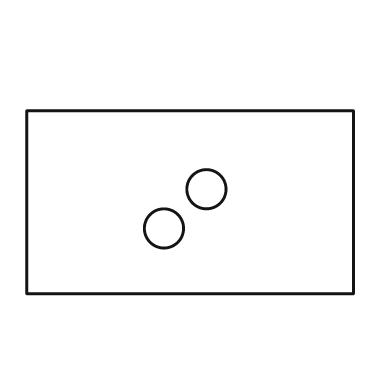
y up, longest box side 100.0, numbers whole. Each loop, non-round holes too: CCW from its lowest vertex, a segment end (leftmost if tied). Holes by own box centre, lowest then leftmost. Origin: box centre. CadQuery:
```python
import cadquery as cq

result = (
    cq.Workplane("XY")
    .moveTo(-50.0, -28.0)
    .lineTo(50.0, -28.0)
    .lineTo(50.0, 28.0)
    .lineTo(-50.0, 28.0)
    .close()
    .moveTo(-8.0, -8.0)
    .circle(6.0)
    .moveTo(5.0, 4.0)
    .circle(6.0)
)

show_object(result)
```